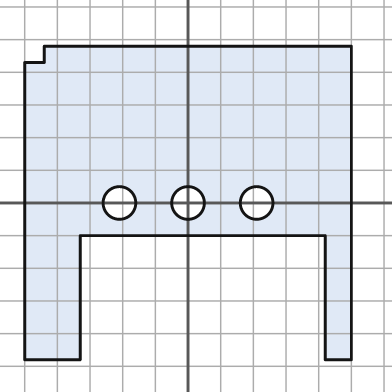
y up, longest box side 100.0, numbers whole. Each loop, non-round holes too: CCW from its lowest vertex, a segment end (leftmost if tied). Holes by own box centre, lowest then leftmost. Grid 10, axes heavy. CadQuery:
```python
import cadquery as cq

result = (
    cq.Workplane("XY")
    .moveTo(-50.0, -48.0)
    .lineTo(-33.0, -48.0)
    .lineTo(-33.0, -10.0)
    .lineTo(42.0, -10.0)
    .lineTo(42.0, -48.0)
    .lineTo(50.0, -48.0)
    .lineTo(50.0, 48.0)
    .lineTo(-44.0, 48.0)
    .lineTo(-44.0, 43.0)
    .lineTo(-50.0, 43.0)
    .close()
    .moveTo(-21.0, 0.0)
    .circle(5.0)
    .moveTo(0.0, 0.0)
    .circle(5.0)
    .moveTo(21.0, 0.0)
    .circle(5.0)
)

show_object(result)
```